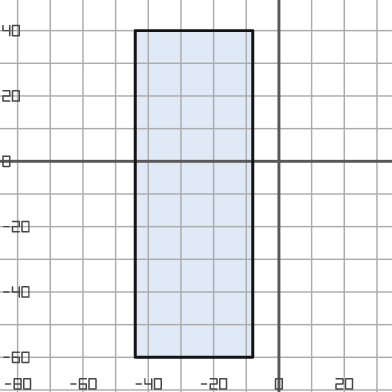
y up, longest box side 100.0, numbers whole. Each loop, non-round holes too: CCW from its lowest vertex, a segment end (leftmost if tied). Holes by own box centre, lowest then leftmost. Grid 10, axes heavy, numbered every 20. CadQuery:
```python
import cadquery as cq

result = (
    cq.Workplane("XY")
    .moveTo(-44.0, -60.0)
    .lineTo(-8.0, -60.0)
    .lineTo(-8.0, 40.0)
    .lineTo(-44.0, 40.0)
    .close()
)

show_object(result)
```